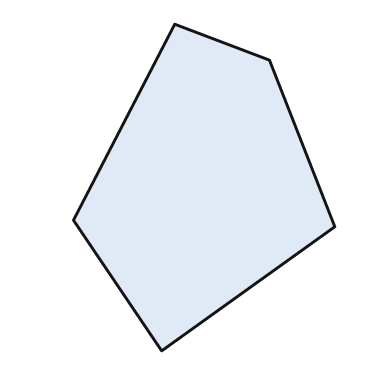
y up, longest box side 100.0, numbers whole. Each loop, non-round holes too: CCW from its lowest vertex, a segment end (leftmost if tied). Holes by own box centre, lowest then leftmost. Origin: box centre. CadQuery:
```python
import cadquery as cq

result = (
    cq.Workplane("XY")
    .moveTo(-13.0, -50.0)
    .lineTo(40.0, -12.0)
    .lineTo(20.0, 39.0)
    .lineTo(-9.0, 50.0)
    .lineTo(-40.0, -10.0)
    .close()
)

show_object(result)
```